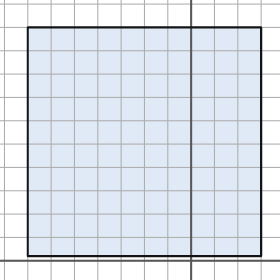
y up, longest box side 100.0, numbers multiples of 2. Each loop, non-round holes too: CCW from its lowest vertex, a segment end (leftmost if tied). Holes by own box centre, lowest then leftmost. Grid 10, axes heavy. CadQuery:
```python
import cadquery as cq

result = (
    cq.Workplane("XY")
    .moveTo(-70.0, 2.0)
    .lineTo(30.0, 2.0)
    .lineTo(30.0, 100.0)
    .lineTo(-70.0, 100.0)
    .close()
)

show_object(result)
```